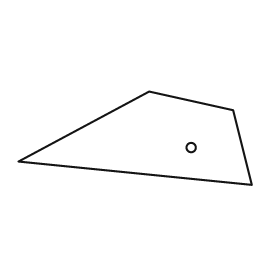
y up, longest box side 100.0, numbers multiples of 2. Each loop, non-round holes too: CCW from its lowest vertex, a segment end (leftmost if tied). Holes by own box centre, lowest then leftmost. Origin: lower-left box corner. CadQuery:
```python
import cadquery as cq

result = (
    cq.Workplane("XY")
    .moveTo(100.0, 0.0)
    .lineTo(92.0, 32.0)
    .lineTo(56.0, 40.0)
    .lineTo(0.0, 10.0)
    .close()
    .moveTo(74.0, 16.0)
    .circle(2.0)
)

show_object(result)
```